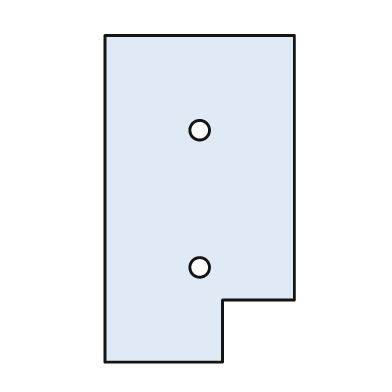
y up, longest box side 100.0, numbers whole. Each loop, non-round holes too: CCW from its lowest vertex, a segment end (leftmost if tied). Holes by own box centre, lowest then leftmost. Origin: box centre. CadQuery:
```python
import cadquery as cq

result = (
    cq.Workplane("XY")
    .moveTo(-29.0, -50.0)
    .lineTo(7.0, -50.0)
    .lineTo(7.0, -31.0)
    .lineTo(29.0, -31.0)
    .lineTo(29.0, 50.0)
    .lineTo(-29.0, 50.0)
    .close()
    .moveTo(0.0, -21.0)
    .circle(3.0)
    .moveTo(0.0, 21.0)
    .circle(3.0)
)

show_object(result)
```